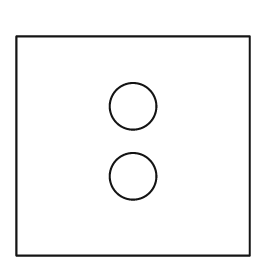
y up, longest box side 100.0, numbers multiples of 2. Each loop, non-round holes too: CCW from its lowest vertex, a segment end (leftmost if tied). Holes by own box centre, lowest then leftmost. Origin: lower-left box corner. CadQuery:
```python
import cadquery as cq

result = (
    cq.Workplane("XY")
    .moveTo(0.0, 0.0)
    .lineTo(100.0, 0.0)
    .lineTo(100.0, 94.0)
    .lineTo(0.0, 94.0)
    .close()
    .moveTo(50.0, 34.0)
    .circle(10.0)
    .moveTo(50.0, 64.0)
    .circle(10.0)
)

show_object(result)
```